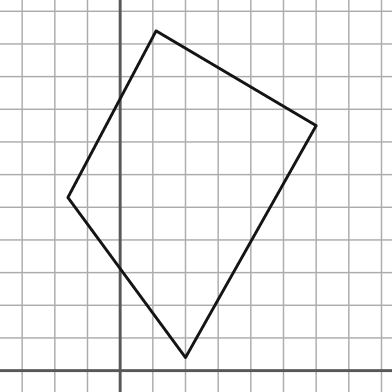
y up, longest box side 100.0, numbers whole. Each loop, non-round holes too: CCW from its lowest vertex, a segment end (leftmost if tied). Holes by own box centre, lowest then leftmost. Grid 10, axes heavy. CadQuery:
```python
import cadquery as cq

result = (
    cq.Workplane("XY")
    .moveTo(20.0, 4.0)
    .lineTo(60.0, 75.0)
    .lineTo(11.0, 104.0)
    .lineTo(-16.0, 53.0)
    .close()
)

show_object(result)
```